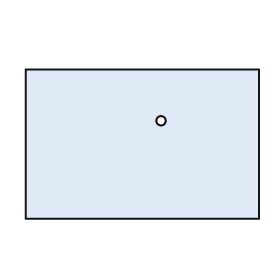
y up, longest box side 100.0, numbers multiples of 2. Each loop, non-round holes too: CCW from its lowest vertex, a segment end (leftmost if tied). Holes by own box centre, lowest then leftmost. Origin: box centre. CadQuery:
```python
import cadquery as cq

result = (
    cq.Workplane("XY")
    .moveTo(-50.0, -32.0)
    .lineTo(50.0, -32.0)
    .lineTo(50.0, 32.0)
    .lineTo(-50.0, 32.0)
    .close()
    .moveTo(8.0, 10.0)
    .circle(2.0)
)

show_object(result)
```